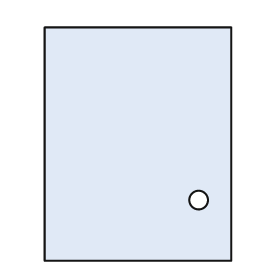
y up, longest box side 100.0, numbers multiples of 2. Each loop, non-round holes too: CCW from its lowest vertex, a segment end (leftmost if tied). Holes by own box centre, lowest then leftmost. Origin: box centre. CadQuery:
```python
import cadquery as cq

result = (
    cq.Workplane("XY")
    .moveTo(-40.0, -50.0)
    .lineTo(40.0, -50.0)
    .lineTo(40.0, 50.0)
    .lineTo(-40.0, 50.0)
    .close()
    .moveTo(26.0, -24.0)
    .circle(4.0)
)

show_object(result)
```